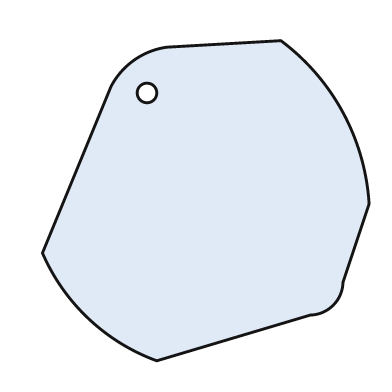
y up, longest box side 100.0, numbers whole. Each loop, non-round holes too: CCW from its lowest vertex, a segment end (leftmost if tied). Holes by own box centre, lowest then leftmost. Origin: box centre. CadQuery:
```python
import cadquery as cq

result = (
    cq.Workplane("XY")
    .moveTo(-15.0, -49.0)
    .lineTo(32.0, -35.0)
    .threePointArc((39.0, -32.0), (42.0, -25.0))
    .lineTo(50.0, -1.0)
    .threePointArc((42.0, 27.0), (23.0, 49.0))
    .lineTo(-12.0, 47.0)
    .threePointArc((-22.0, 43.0), (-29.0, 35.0))
    .lineTo(-50.0, -16.0)
    .threePointArc((-36.0, -36.0), (-15.0, -49.0))
    .close()
    .moveTo(-18.0, 33.0)
    .circle(3.0)
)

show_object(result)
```